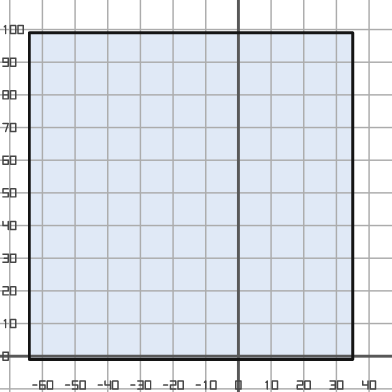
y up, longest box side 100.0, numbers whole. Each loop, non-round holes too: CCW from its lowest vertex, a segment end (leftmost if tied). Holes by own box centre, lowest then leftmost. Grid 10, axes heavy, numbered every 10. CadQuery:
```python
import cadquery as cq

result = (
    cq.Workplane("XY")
    .moveTo(-64.0, -1.0)
    .lineTo(35.0, -1.0)
    .lineTo(35.0, 99.0)
    .lineTo(-64.0, 99.0)
    .close()
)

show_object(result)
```